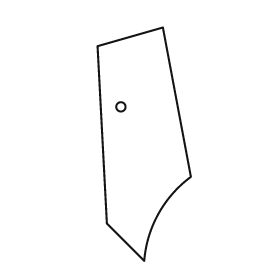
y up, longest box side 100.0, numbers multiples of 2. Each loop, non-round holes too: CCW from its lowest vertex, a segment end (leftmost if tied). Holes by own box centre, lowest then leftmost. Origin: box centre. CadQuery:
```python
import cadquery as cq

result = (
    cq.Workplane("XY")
    .moveTo(0.0, -50.0)
    .threePointArc((6.0, -30.0), (20.0, -14.0))
    .lineTo(8.0, 50.0)
    .lineTo(-20.0, 42.0)
    .lineTo(-16.0, -34.0)
    .close()
    .moveTo(-10.0, 16.0)
    .circle(2.0)
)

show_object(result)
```